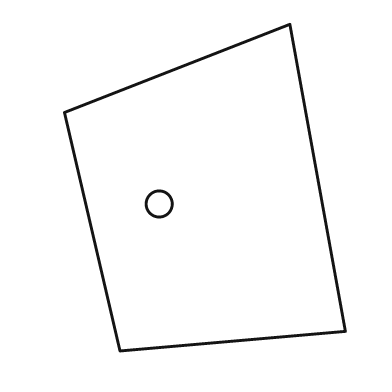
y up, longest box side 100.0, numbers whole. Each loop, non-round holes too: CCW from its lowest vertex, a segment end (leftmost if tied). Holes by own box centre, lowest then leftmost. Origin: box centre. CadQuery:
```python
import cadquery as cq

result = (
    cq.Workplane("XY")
    .moveTo(-26.0, -50.0)
    .lineTo(43.0, -44.0)
    .lineTo(26.0, 50.0)
    .lineTo(-43.0, 23.0)
    .close()
    .moveTo(-14.0, -5.0)
    .circle(4.0)
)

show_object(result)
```